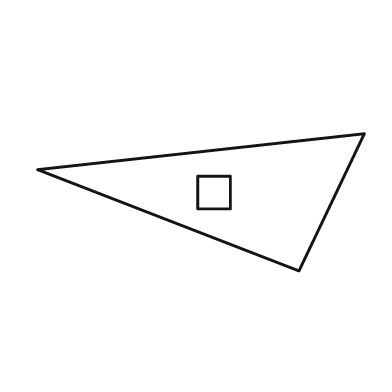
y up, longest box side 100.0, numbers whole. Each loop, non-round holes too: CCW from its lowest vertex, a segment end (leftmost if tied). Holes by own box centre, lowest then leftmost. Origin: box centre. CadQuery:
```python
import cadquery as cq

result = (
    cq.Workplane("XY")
    .moveTo(30.0, -21.0)
    .lineTo(50.0, 21.0)
    .lineTo(-50.0, 10.0)
    .close()
    .moveTo(-1.0, -2.0)
    .lineTo(9.0, -2.0)
    .lineTo(9.0, 8.0)
    .lineTo(-1.0, 8.0)
    .close()
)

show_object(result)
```